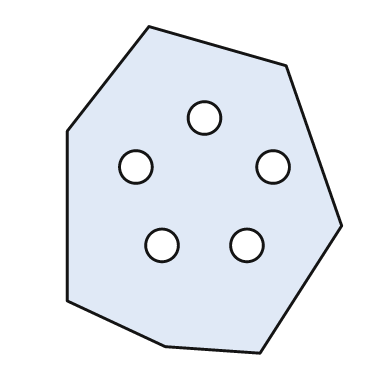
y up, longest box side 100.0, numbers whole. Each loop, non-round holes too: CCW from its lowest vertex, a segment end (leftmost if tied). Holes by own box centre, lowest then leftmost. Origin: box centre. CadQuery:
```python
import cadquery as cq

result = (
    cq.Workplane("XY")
    .moveTo(17.0, -50.0)
    .lineTo(42.0, -11.0)
    .lineTo(25.0, 38.0)
    .lineTo(-17.0, 50.0)
    .lineTo(-42.0, 18.0)
    .lineTo(-42.0, -34.0)
    .lineTo(-12.0, -48.0)
    .close()
    .moveTo(-13.0, -17.0)
    .circle(5.0)
    .moveTo(13.0, -17.0)
    .circle(5.0)
    .moveTo(-21.0, 7.0)
    .circle(5.0)
    .moveTo(21.0, 7.0)
    .circle(5.0)
    .moveTo(0.0, 22.0)
    .circle(5.0)
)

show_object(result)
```